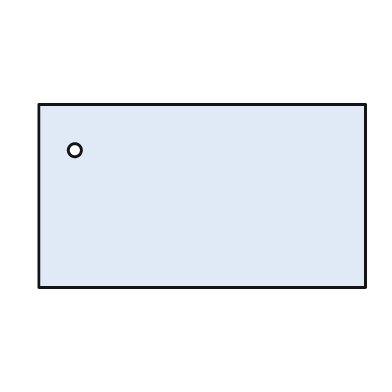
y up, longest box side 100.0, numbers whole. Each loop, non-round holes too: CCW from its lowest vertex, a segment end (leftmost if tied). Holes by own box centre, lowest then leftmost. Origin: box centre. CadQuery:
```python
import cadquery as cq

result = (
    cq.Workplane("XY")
    .moveTo(-50.0, -28.0)
    .lineTo(50.0, -28.0)
    .lineTo(50.0, 28.0)
    .lineTo(-50.0, 28.0)
    .close()
    .moveTo(-39.0, 14.0)
    .circle(2.0)
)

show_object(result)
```